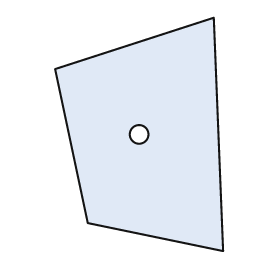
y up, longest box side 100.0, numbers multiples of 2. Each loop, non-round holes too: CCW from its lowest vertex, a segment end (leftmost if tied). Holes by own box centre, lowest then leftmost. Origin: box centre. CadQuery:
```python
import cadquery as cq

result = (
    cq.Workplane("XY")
    .moveTo(36.0, -50.0)
    .lineTo(32.0, 50.0)
    .lineTo(-36.0, 28.0)
    .lineTo(-22.0, -38.0)
    .close()
    .moveTo(0.0, 0.0)
    .circle(4.0)
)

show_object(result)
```